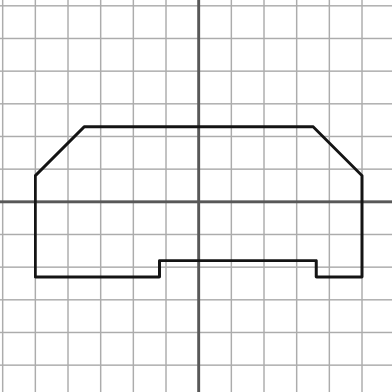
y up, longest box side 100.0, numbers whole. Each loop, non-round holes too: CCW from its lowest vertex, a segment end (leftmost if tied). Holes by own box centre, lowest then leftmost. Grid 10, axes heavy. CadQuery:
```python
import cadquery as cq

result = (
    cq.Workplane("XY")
    .moveTo(-50.0, -23.0)
    .lineTo(-12.0, -23.0)
    .lineTo(-12.0, -18.0)
    .lineTo(36.0, -18.0)
    .lineTo(36.0, -23.0)
    .lineTo(50.0, -23.0)
    .lineTo(50.0, 8.0)
    .lineTo(35.0, 23.0)
    .lineTo(-35.0, 23.0)
    .lineTo(-50.0, 8.0)
    .close()
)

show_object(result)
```